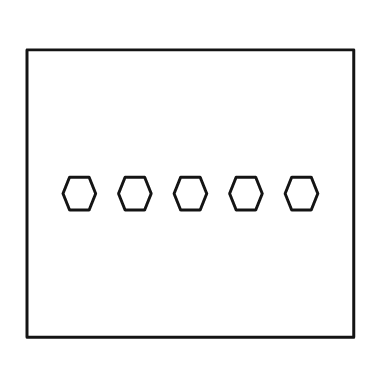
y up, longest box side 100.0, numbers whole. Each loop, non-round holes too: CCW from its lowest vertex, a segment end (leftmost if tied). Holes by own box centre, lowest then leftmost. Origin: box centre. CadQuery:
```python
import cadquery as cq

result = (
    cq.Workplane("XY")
    .moveTo(-50.0, -44.0)
    .lineTo(50.0, -44.0)
    .lineTo(50.0, 44.0)
    .lineTo(-50.0, 44.0)
    .close()
    .moveTo(-37.0, -5.0)
    .lineTo(-31.0, -5.0)
    .lineTo(-29.0, 0.0)
    .lineTo(-31.0, 5.0)
    .lineTo(-37.0, 5.0)
    .lineTo(-39.0, 0.0)
    .close()
    .moveTo(-20.0, -5.0)
    .lineTo(-14.0, -5.0)
    .lineTo(-12.0, 0.0)
    .lineTo(-14.0, 5.0)
    .lineTo(-20.0, 5.0)
    .lineTo(-22.0, 0.0)
    .close()
    .moveTo(-3.0, -5.0)
    .lineTo(3.0, -5.0)
    .lineTo(5.0, 0.0)
    .lineTo(3.0, 5.0)
    .lineTo(-3.0, 5.0)
    .lineTo(-5.0, 0.0)
    .close()
    .moveTo(14.0, -5.0)
    .lineTo(20.0, -5.0)
    .lineTo(22.0, 0.0)
    .lineTo(20.0, 5.0)
    .lineTo(14.0, 5.0)
    .lineTo(12.0, 0.0)
    .close()
    .moveTo(31.0, -5.0)
    .lineTo(37.0, -5.0)
    .lineTo(39.0, 0.0)
    .lineTo(37.0, 5.0)
    .lineTo(31.0, 5.0)
    .lineTo(29.0, 0.0)
    .close()
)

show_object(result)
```